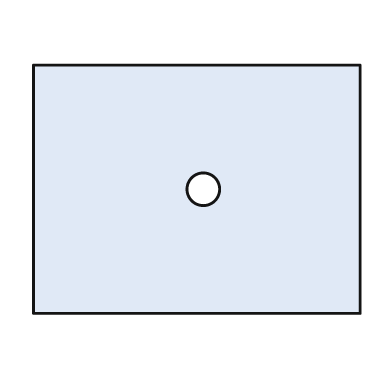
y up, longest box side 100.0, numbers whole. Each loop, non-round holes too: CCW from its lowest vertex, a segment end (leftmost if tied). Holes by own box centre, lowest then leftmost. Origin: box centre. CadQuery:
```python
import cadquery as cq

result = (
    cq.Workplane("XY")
    .moveTo(-50.0, -38.0)
    .lineTo(50.0, -38.0)
    .lineTo(50.0, 38.0)
    .lineTo(-50.0, 38.0)
    .close()
    .moveTo(2.0, 0.0)
    .circle(5.0)
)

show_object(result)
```